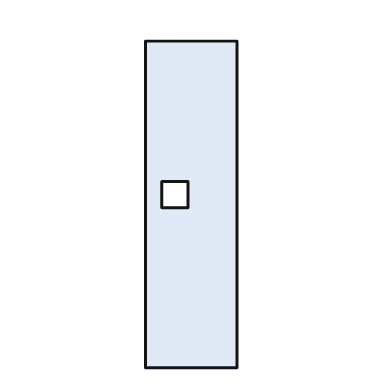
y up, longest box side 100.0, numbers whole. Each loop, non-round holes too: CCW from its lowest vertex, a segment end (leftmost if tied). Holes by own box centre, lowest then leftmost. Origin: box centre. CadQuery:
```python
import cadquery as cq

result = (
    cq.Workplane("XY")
    .moveTo(-14.0, -50.0)
    .lineTo(14.0, -50.0)
    .lineTo(14.0, 50.0)
    .lineTo(-14.0, 50.0)
    .close()
    .moveTo(-9.0, -1.0)
    .lineTo(-1.0, -1.0)
    .lineTo(-1.0, 7.0)
    .lineTo(-9.0, 7.0)
    .close()
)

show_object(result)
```